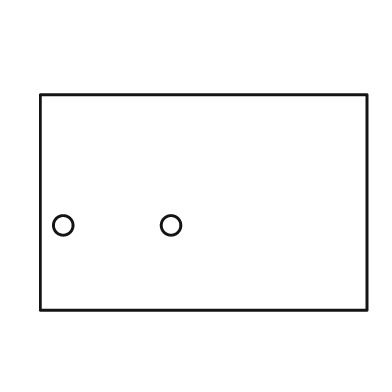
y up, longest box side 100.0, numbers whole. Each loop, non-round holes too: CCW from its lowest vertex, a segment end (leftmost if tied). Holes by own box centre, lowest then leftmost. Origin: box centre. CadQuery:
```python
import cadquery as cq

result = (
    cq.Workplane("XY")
    .moveTo(-50.0, -33.0)
    .lineTo(50.0, -33.0)
    .lineTo(50.0, 33.0)
    .lineTo(-50.0, 33.0)
    .close()
    .moveTo(-43.0, -7.0)
    .circle(3.0)
    .moveTo(-10.0, -7.0)
    .circle(3.0)
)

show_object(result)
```